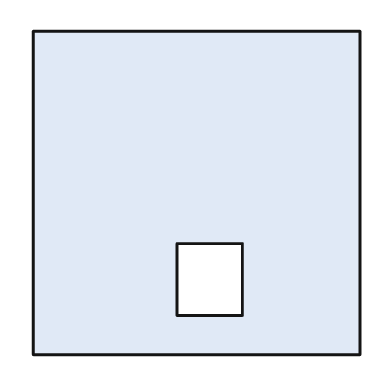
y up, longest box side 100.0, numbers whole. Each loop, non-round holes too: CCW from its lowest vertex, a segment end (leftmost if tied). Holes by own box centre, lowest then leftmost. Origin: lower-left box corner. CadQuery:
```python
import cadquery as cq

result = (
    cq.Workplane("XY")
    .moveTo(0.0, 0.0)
    .lineTo(100.0, 0.0)
    .lineTo(100.0, 99.0)
    .lineTo(0.0, 99.0)
    .close()
    .moveTo(44.0, 12.0)
    .lineTo(64.0, 12.0)
    .lineTo(64.0, 34.0)
    .lineTo(44.0, 34.0)
    .close()
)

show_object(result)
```